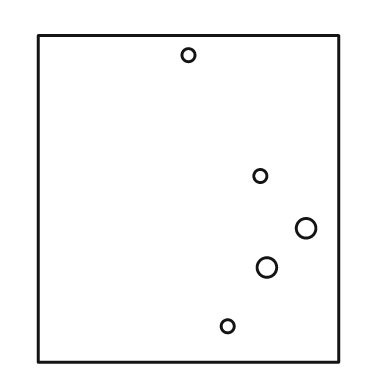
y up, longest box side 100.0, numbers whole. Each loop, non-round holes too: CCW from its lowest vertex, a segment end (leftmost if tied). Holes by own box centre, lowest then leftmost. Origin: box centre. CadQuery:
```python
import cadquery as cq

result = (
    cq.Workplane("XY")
    .moveTo(-46.0, -50.0)
    .lineTo(46.0, -50.0)
    .lineTo(46.0, 50.0)
    .lineTo(-46.0, 50.0)
    .close()
    .moveTo(12.0, -39.0)
    .circle(2.0)
    .moveTo(24.0, -21.0)
    .circle(3.0)
    .moveTo(36.0, -9.0)
    .circle(3.0)
    .moveTo(22.0, 7.0)
    .circle(2.0)
    .moveTo(0.0, 44.0)
    .circle(2.0)
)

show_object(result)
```